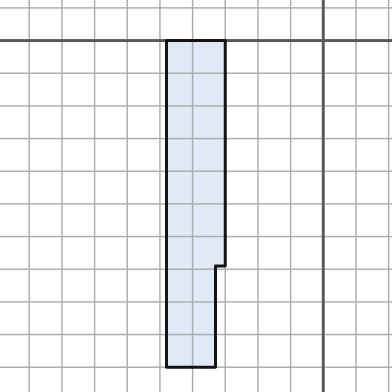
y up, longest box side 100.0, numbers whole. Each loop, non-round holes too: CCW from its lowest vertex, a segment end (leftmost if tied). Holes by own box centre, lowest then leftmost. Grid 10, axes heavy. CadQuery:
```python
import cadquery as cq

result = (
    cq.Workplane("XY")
    .moveTo(-48.0, -100.0)
    .lineTo(-33.0, -100.0)
    .lineTo(-33.0, -69.0)
    .lineTo(-30.0, -69.0)
    .lineTo(-30.0, 0.0)
    .lineTo(-48.0, 0.0)
    .close()
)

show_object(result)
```